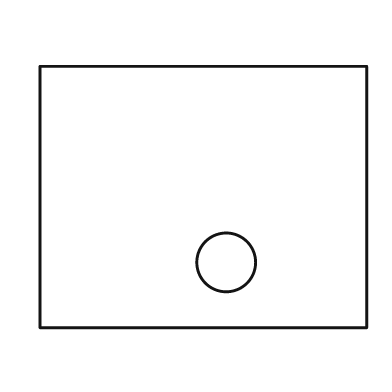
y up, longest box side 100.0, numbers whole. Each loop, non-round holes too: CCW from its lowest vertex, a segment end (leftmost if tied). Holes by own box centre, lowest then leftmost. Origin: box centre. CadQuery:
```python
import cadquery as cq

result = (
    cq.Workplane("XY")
    .moveTo(-50.0, -40.0)
    .lineTo(50.0, -40.0)
    .lineTo(50.0, 40.0)
    .lineTo(-50.0, 40.0)
    .close()
    .moveTo(7.0, -20.0)
    .circle(9.0)
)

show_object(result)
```